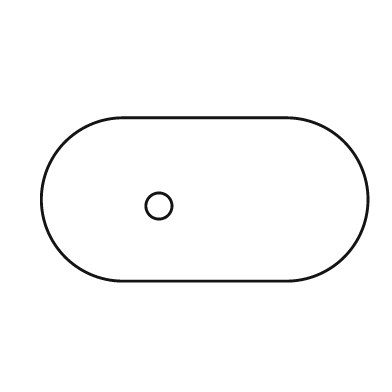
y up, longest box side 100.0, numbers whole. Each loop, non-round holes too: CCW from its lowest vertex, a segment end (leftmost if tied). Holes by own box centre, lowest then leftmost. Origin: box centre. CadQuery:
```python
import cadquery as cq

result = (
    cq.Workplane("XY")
    .moveTo(-25.0, -25.0)
    .lineTo(25.0, -25.0)
    .threePointArc((50.0, 0.0), (25.0, 25.0))
    .lineTo(-25.0, 25.0)
    .threePointArc((-50.0, 0.0), (-25.0, -25.0))
    .close()
    .moveTo(-14.0, -2.0)
    .circle(4.0)
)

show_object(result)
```